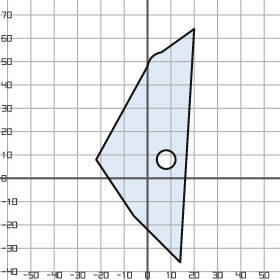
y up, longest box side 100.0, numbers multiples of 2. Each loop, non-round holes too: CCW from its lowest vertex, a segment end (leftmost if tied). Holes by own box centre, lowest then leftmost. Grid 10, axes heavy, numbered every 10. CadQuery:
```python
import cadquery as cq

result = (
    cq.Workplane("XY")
    .moveTo(14.0, -36.0)
    .lineTo(20.0, 64.0)
    .lineTo(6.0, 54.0)
    .threePointArc((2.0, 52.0), (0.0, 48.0))
    .lineTo(-22.0, 8.0)
    .lineTo(-6.0, -16.0)
    .close()
    .moveTo(8.0, 8.0)
    .circle(4.0)
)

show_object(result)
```